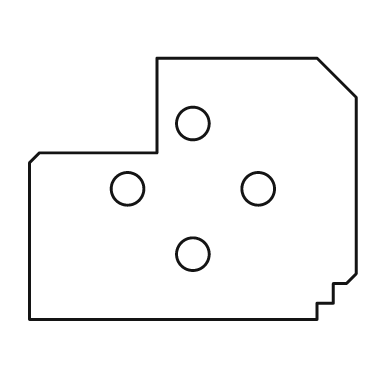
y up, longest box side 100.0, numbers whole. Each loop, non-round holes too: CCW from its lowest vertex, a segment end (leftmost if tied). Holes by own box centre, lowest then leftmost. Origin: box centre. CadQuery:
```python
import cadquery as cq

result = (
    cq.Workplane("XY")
    .moveTo(-50.0, -40.0)
    .lineTo(38.0, -40.0)
    .lineTo(38.0, -35.0)
    .lineTo(43.0, -35.0)
    .lineTo(43.0, -29.0)
    .lineTo(47.0, -29.0)
    .lineTo(50.0, -26.0)
    .lineTo(50.0, 28.0)
    .lineTo(38.0, 40.0)
    .lineTo(-11.0, 40.0)
    .lineTo(-11.0, 11.0)
    .lineTo(-47.0, 11.0)
    .lineTo(-50.0, 8.0)
    .close()
    .moveTo(0.0, -20.0)
    .circle(5.0)
    .moveTo(-20.0, 0.0)
    .circle(5.0)
    .moveTo(20.0, 0.0)
    .circle(5.0)
    .moveTo(0.0, 20.0)
    .circle(5.0)
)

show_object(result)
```